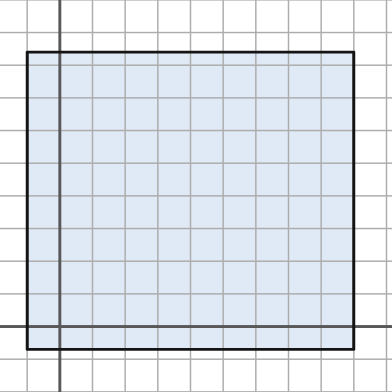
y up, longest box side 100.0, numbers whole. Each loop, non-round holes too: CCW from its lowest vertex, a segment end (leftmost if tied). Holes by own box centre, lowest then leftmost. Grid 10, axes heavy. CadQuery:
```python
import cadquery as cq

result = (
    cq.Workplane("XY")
    .moveTo(-10.0, -7.0)
    .lineTo(90.0, -7.0)
    .lineTo(90.0, 84.0)
    .lineTo(-10.0, 84.0)
    .close()
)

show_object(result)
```